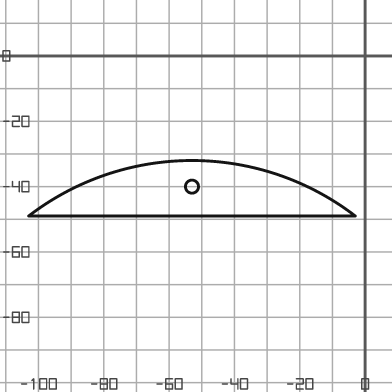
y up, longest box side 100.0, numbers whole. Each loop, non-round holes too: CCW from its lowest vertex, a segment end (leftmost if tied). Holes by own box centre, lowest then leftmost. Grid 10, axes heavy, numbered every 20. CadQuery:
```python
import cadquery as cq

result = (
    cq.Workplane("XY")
    .moveTo(-103.0, -49.0)
    .lineTo(-3.0, -49.0)
    .threePointArc((-53.0, -32.0), (-103.0, -49.0))
    .close()
    .moveTo(-53.0, -40.0)
    .circle(2.0)
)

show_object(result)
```